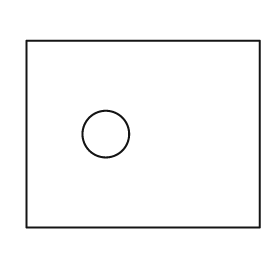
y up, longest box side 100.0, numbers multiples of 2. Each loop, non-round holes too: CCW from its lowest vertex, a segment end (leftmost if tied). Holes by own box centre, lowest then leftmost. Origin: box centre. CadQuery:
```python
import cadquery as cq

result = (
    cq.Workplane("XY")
    .moveTo(-50.0, -40.0)
    .lineTo(50.0, -40.0)
    .lineTo(50.0, 40.0)
    .lineTo(-50.0, 40.0)
    .close()
    .moveTo(-16.0, 0.0)
    .circle(10.0)
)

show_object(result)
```